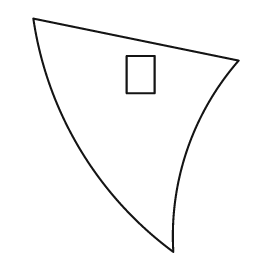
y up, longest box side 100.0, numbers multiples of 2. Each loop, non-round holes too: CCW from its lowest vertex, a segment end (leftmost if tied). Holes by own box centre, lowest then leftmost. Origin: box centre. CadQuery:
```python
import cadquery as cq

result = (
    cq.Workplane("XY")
    .moveTo(16.0, -50.0)
    .threePointArc((22.0, -6.0), (44.0, 32.0))
    .lineTo(-44.0, 50.0)
    .threePointArc((-24.0, -6.0), (16.0, -50.0))
    .close()
    .moveTo(-4.0, 18.0)
    .lineTo(8.0, 18.0)
    .lineTo(8.0, 34.0)
    .lineTo(-4.0, 34.0)
    .close()
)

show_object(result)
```